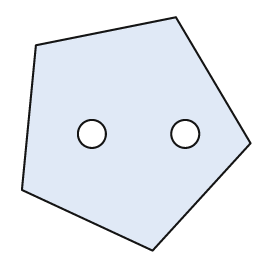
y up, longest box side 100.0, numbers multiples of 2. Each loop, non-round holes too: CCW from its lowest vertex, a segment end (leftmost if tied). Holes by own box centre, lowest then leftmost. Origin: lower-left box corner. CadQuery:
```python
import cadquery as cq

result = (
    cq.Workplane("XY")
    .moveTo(56.0, 0.0)
    .lineTo(98.0, 46.0)
    .lineTo(66.0, 100.0)
    .lineTo(6.0, 88.0)
    .lineTo(0.0, 26.0)
    .close()
    .moveTo(30.0, 50.0)
    .circle(6.0)
    .moveTo(70.0, 50.0)
    .circle(6.0)
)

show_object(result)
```